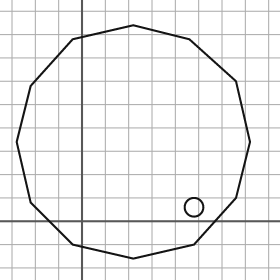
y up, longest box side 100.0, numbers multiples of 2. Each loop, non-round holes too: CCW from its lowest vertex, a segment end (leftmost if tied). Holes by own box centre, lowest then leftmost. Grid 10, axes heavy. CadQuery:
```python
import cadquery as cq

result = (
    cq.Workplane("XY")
    .moveTo(22.0, -16.0)
    .lineTo(48.0, -10.0)
    .lineTo(66.0, 10.0)
    .lineTo(72.0, 34.0)
    .lineTo(66.0, 60.0)
    .lineTo(46.0, 78.0)
    .lineTo(22.0, 84.0)
    .lineTo(-4.0, 78.0)
    .lineTo(-22.0, 58.0)
    .lineTo(-28.0, 34.0)
    .lineTo(-22.0, 8.0)
    .lineTo(-4.0, -10.0)
    .close()
    .moveTo(48.0, 6.0)
    .circle(4.0)
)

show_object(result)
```